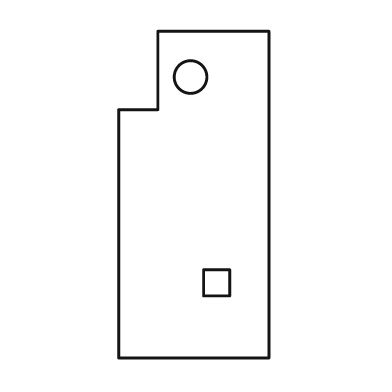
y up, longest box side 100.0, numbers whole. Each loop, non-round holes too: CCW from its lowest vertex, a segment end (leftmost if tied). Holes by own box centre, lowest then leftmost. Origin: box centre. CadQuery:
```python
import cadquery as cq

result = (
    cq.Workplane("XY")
    .moveTo(-23.0, -50.0)
    .lineTo(23.0, -50.0)
    .lineTo(23.0, 50.0)
    .lineTo(-11.0, 50.0)
    .lineTo(-11.0, 26.0)
    .lineTo(-23.0, 26.0)
    .close()
    .moveTo(3.0, -31.0)
    .lineTo(11.0, -31.0)
    .lineTo(11.0, -23.0)
    .lineTo(3.0, -23.0)
    .close()
    .moveTo(-1.0, 36.0)
    .circle(5.0)
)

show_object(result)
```